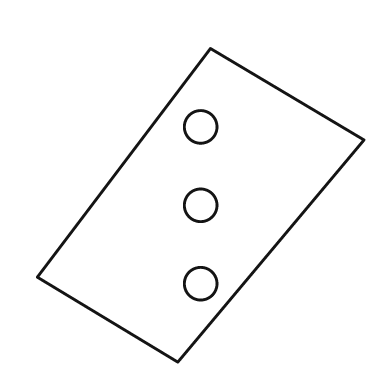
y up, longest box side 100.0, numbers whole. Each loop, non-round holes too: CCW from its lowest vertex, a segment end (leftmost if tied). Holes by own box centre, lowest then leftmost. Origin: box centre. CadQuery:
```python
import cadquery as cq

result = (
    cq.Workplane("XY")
    .moveTo(-7.0, -48.0)
    .lineTo(50.0, 20.0)
    .lineTo(3.0, 48.0)
    .lineTo(-50.0, -22.0)
    .close()
    .moveTo(0.0, -24.0)
    .circle(5.0)
    .moveTo(0.0, 0.0)
    .circle(5.0)
    .moveTo(0.0, 24.0)
    .circle(5.0)
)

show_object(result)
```